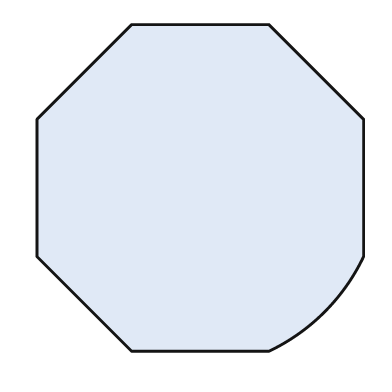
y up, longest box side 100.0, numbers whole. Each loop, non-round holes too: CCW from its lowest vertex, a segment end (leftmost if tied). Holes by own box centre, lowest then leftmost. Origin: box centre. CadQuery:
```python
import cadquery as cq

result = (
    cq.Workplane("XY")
    .moveTo(-21.0, -50.0)
    .lineTo(21.0, -50.0)
    .threePointArc((38.0, -38.0), (50.0, -21.0))
    .lineTo(50.0, 21.0)
    .lineTo(21.0, 50.0)
    .lineTo(-21.0, 50.0)
    .lineTo(-50.0, 21.0)
    .lineTo(-50.0, -21.0)
    .close()
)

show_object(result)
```